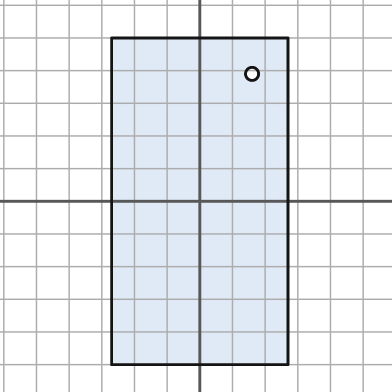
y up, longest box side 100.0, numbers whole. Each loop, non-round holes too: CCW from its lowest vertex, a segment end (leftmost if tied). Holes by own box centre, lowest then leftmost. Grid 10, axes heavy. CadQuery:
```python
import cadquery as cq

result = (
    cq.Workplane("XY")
    .moveTo(-27.0, -50.0)
    .lineTo(27.0, -50.0)
    .lineTo(27.0, 50.0)
    .lineTo(-27.0, 50.0)
    .close()
    .moveTo(16.0, 39.0)
    .circle(2.0)
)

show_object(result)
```